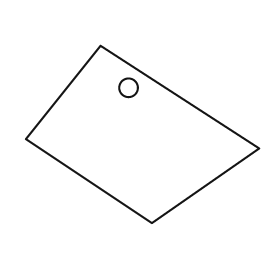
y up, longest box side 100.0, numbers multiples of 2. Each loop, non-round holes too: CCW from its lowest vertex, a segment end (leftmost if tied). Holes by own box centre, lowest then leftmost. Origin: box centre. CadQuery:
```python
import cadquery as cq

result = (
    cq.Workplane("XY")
    .moveTo(4.0, -38.0)
    .lineTo(50.0, -6.0)
    .lineTo(-18.0, 38.0)
    .lineTo(-50.0, -2.0)
    .close()
    .moveTo(-6.0, 20.0)
    .circle(4.0)
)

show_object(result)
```